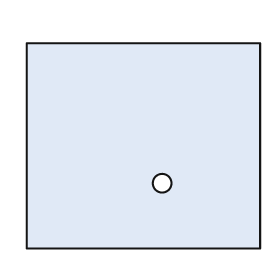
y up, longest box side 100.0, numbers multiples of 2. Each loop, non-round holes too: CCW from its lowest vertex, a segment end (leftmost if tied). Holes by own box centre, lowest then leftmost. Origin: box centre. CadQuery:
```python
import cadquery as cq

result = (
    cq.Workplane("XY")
    .moveTo(-50.0, -44.0)
    .lineTo(50.0, -44.0)
    .lineTo(50.0, 44.0)
    .lineTo(-50.0, 44.0)
    .close()
    .moveTo(8.0, -16.0)
    .circle(4.0)
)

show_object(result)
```